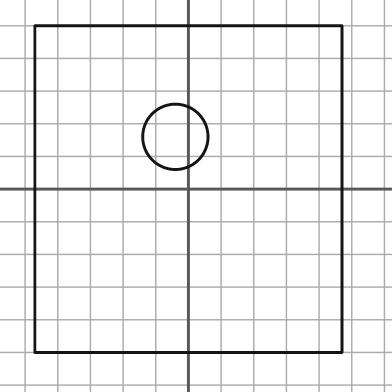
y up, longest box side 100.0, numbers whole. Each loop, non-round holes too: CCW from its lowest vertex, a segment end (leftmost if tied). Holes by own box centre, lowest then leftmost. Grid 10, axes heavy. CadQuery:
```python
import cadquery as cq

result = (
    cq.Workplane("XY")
    .moveTo(-47.0, -50.0)
    .lineTo(47.0, -50.0)
    .lineTo(47.0, 50.0)
    .lineTo(-47.0, 50.0)
    .close()
    .moveTo(-4.0, 16.0)
    .circle(10.0)
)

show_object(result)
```